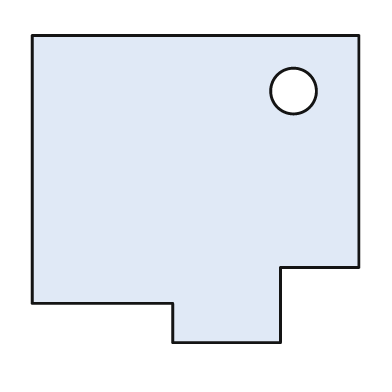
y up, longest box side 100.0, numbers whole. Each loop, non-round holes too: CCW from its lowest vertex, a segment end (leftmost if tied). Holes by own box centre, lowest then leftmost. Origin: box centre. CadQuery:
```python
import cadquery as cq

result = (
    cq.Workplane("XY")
    .moveTo(-7.0, -47.0)
    .lineTo(26.0, -47.0)
    .lineTo(26.0, -24.0)
    .lineTo(50.0, -24.0)
    .lineTo(50.0, 47.0)
    .lineTo(-50.0, 47.0)
    .lineTo(-50.0, -35.0)
    .lineTo(-7.0, -35.0)
    .close()
    .moveTo(30.0, 30.0)
    .circle(7.0)
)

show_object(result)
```